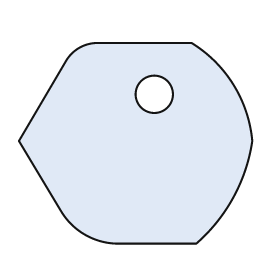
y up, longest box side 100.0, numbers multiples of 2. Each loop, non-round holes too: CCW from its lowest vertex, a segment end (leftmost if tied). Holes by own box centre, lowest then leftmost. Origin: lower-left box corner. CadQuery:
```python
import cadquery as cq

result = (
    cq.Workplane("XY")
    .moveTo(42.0, 0.0)
    .lineTo(76.0, 0.0)
    .threePointArc((92.0, 20.0), (100.0, 44.0))
    .threePointArc((92.0, 68.0), (74.0, 86.0))
    .lineTo(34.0, 86.0)
    .threePointArc((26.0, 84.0), (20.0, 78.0))
    .lineTo(0.0, 44.0)
    .lineTo(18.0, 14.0)
    .threePointArc((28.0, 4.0), (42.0, 0.0))
    .close()
    .moveTo(58.0, 64.0)
    .circle(8.0)
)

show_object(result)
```